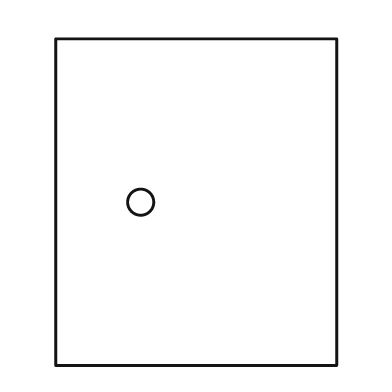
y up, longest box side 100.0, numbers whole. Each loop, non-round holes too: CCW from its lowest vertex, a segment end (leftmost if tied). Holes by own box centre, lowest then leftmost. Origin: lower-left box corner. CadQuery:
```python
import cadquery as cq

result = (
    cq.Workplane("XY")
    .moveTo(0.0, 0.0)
    .lineTo(86.0, 0.0)
    .lineTo(86.0, 100.0)
    .lineTo(0.0, 100.0)
    .close()
    .moveTo(26.0, 50.0)
    .circle(4.0)
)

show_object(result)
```